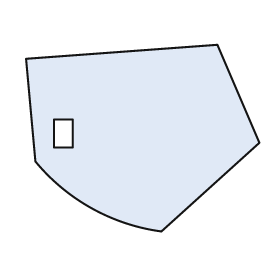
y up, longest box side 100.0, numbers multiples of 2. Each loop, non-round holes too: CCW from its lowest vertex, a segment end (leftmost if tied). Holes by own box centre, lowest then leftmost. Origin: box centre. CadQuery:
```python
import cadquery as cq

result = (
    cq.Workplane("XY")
    .moveTo(8.0, -40.0)
    .lineTo(50.0, -2.0)
    .lineTo(32.0, 40.0)
    .lineTo(-50.0, 34.0)
    .lineTo(-46.0, -10.0)
    .threePointArc((-22.0, -30.0), (8.0, -40.0))
    .close()
    .moveTo(-38.0, -4.0)
    .lineTo(-30.0, -4.0)
    .lineTo(-30.0, 8.0)
    .lineTo(-38.0, 8.0)
    .close()
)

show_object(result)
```